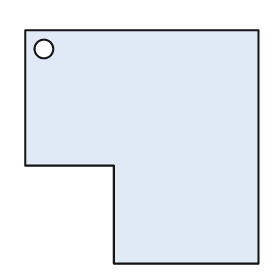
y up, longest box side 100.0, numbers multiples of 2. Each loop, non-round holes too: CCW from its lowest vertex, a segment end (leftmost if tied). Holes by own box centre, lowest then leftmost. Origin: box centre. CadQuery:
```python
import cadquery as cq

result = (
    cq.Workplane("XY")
    .moveTo(-12.0, -50.0)
    .lineTo(50.0, -50.0)
    .lineTo(50.0, 50.0)
    .lineTo(-50.0, 50.0)
    .lineTo(-50.0, -8.0)
    .lineTo(-12.0, -8.0)
    .close()
    .moveTo(-42.0, 42.0)
    .circle(4.0)
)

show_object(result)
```